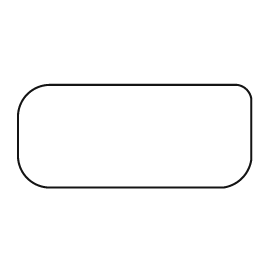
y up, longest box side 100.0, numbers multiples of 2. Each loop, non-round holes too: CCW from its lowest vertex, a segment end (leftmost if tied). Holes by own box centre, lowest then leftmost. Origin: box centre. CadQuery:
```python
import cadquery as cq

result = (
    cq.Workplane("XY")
    .moveTo(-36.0, -22.0)
    .lineTo(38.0, -22.0)
    .threePointArc((46.0, -18.0), (50.0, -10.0))
    .lineTo(50.0, 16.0)
    .threePointArc((48.0, 20.0), (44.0, 22.0))
    .lineTo(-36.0, 22.0)
    .threePointArc((-46.0, 18.0), (-50.0, 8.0))
    .lineTo(-50.0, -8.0)
    .threePointArc((-46.0, -18.0), (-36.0, -22.0))
    .close()
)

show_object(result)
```